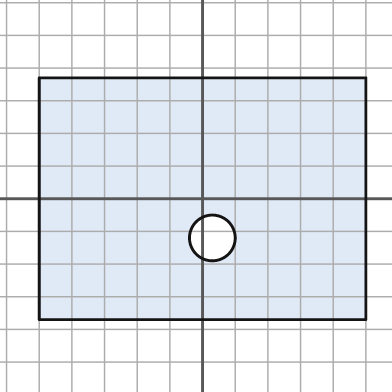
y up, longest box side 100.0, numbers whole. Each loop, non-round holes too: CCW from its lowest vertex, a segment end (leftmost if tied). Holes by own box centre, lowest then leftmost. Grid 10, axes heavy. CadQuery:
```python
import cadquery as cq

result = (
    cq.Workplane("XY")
    .moveTo(-50.0, -37.0)
    .lineTo(50.0, -37.0)
    .lineTo(50.0, 37.0)
    .lineTo(-50.0, 37.0)
    .close()
    .moveTo(3.0, -12.0)
    .circle(7.0)
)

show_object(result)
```